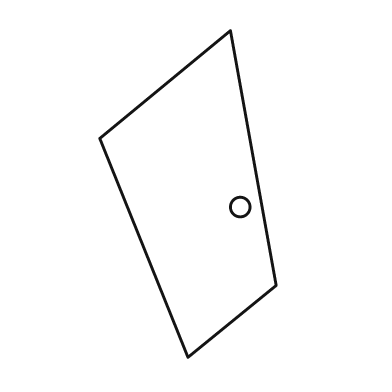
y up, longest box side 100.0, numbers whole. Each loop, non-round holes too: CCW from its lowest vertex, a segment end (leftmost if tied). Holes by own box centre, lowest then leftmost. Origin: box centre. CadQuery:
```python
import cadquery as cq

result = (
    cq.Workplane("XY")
    .moveTo(0.0, -50.0)
    .lineTo(27.0, -28.0)
    .lineTo(13.0, 50.0)
    .lineTo(-27.0, 17.0)
    .close()
    .moveTo(16.0, -4.0)
    .circle(3.0)
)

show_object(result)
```